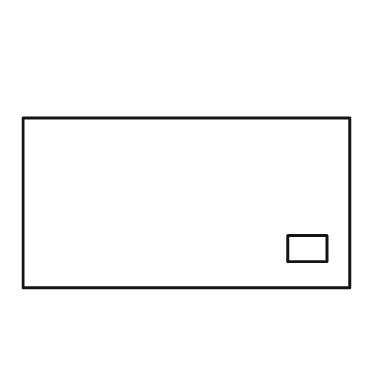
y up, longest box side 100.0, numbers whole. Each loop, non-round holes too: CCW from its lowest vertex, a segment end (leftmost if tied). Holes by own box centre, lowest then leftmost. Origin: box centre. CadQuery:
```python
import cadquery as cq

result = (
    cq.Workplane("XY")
    .moveTo(-50.0, -26.0)
    .lineTo(50.0, -26.0)
    .lineTo(50.0, 26.0)
    .lineTo(-50.0, 26.0)
    .close()
    .moveTo(31.0, -18.0)
    .lineTo(43.0, -18.0)
    .lineTo(43.0, -10.0)
    .lineTo(31.0, -10.0)
    .close()
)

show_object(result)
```